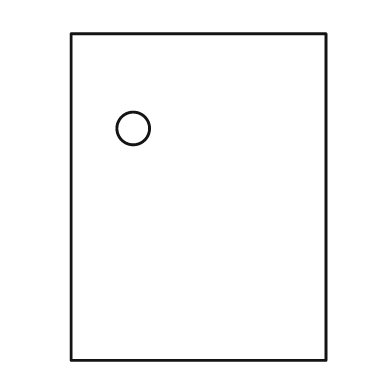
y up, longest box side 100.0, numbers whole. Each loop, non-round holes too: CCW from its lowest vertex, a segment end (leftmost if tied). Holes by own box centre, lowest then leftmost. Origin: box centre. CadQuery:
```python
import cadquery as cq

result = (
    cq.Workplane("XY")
    .moveTo(-39.0, -50.0)
    .lineTo(39.0, -50.0)
    .lineTo(39.0, 50.0)
    .lineTo(-39.0, 50.0)
    .close()
    .moveTo(-20.0, 21.0)
    .circle(5.0)
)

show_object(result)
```